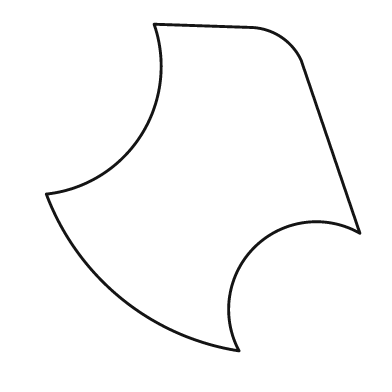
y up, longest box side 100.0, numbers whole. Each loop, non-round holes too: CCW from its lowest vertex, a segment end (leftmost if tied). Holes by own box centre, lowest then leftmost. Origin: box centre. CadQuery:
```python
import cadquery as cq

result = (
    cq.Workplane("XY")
    .moveTo(11.0, -50.0)
    .threePointArc((16.0, -18.0), (48.0, -14.0))
    .lineTo(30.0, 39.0)
    .threePointArc((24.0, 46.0), (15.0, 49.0))
    .lineTo(-15.0, 50.0)
    .threePointArc((-19.0, 16.0), (-48.0, -2.0))
    .threePointArc((-25.0, -34.0), (11.0, -50.0))
    .close()
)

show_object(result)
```